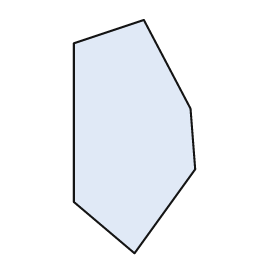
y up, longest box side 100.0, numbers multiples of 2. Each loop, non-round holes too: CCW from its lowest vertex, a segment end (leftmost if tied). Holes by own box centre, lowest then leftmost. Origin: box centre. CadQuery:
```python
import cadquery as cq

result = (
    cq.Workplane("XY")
    .moveTo(0.0, -50.0)
    .lineTo(26.0, -14.0)
    .lineTo(24.0, 12.0)
    .lineTo(4.0, 50.0)
    .lineTo(-26.0, 40.0)
    .lineTo(-26.0, -28.0)
    .close()
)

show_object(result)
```